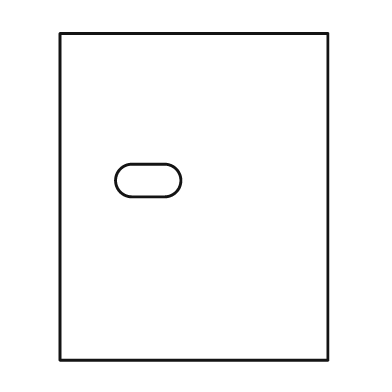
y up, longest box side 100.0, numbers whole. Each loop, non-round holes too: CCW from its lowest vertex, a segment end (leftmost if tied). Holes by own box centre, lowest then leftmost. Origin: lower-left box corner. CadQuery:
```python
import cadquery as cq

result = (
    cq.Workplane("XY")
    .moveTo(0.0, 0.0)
    .lineTo(82.0, 0.0)
    .lineTo(82.0, 100.0)
    .lineTo(0.0, 100.0)
    .close()
    .moveTo(22.0, 50.0)
    .lineTo(32.0, 50.0)
    .threePointArc((37.0, 55.0), (32.0, 60.0))
    .lineTo(22.0, 60.0)
    .threePointArc((17.0, 55.0), (22.0, 50.0))
    .close()
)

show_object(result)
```